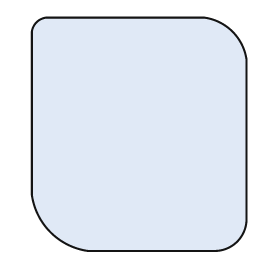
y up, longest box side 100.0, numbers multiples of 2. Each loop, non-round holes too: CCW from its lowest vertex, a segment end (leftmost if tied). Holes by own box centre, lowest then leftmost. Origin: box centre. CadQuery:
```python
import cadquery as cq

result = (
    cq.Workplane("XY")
    .moveTo(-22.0, -50.0)
    .lineTo(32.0, -50.0)
    .threePointArc((42.0, -46.0), (46.0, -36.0))
    .lineTo(46.0, 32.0)
    .threePointArc((40.0, 44.0), (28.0, 50.0))
    .lineTo(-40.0, 50.0)
    .threePointArc((-44.0, 48.0), (-46.0, 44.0))
    .lineTo(-46.0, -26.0)
    .threePointArc((-38.0, -42.0), (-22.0, -50.0))
    .close()
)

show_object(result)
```